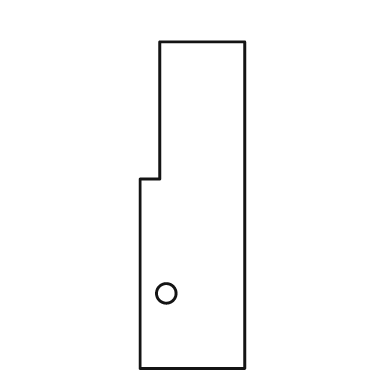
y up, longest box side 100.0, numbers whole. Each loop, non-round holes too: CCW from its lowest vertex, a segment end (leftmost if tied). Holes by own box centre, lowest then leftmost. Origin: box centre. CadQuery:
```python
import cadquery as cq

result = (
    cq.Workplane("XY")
    .moveTo(-16.0, -50.0)
    .lineTo(16.0, -50.0)
    .lineTo(16.0, 50.0)
    .lineTo(-10.0, 50.0)
    .lineTo(-10.0, 8.0)
    .lineTo(-16.0, 8.0)
    .close()
    .moveTo(-8.0, -27.0)
    .circle(3.0)
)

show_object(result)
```